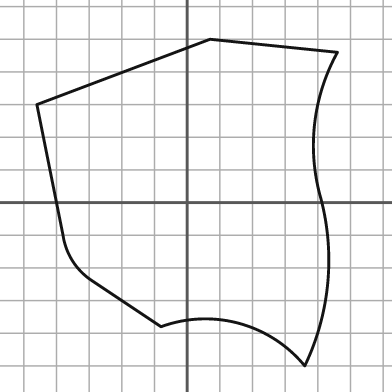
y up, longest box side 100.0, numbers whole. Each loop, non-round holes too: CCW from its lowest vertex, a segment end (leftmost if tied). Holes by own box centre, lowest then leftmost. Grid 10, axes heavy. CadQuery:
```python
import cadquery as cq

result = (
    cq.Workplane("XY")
    .moveTo(36.0, -50.0)
    .threePointArc((43.0, -25.0), (41.0, 1.0))
    .threePointArc((39.0, 24.0), (46.0, 46.0))
    .lineTo(7.0, 50.0)
    .lineTo(-46.0, 30.0)
    .lineTo(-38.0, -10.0)
    .threePointArc((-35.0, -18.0), (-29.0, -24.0))
    .lineTo(-8.0, -38.0)
    .threePointArc((16.0, -37.0), (36.0, -50.0))
    .close()
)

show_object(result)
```